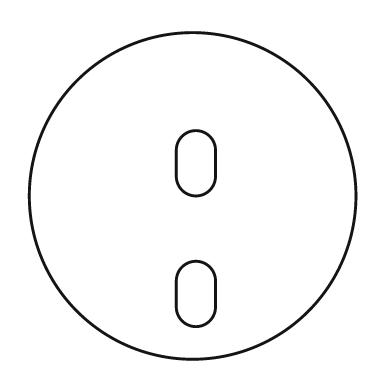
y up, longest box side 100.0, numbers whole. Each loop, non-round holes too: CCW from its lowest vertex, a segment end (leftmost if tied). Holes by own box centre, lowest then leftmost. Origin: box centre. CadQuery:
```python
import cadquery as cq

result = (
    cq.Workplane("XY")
    .moveTo(0.0, 0.0)
    .circle(50.0)
    .moveTo(-5.0, -34.0)
    .threePointArc((1.0, -40.0), (7.0, -34.0))
    .lineTo(7.0, -26.0)
    .threePointArc((1.0, -20.0), (-5.0, -26.0))
    .close()
    .moveTo(-5.0, 6.0)
    .threePointArc((1.0, 0.0), (7.0, 6.0))
    .lineTo(7.0, 14.0)
    .threePointArc((1.0, 20.0), (-5.0, 14.0))
    .close()
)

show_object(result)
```